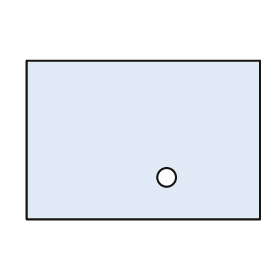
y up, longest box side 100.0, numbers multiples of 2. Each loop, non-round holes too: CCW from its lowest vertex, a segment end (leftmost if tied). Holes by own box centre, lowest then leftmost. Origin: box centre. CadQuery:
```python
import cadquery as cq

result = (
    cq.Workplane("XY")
    .moveTo(-50.0, -34.0)
    .lineTo(50.0, -34.0)
    .lineTo(50.0, 34.0)
    .lineTo(-50.0, 34.0)
    .close()
    .moveTo(10.0, -16.0)
    .circle(4.0)
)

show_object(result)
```